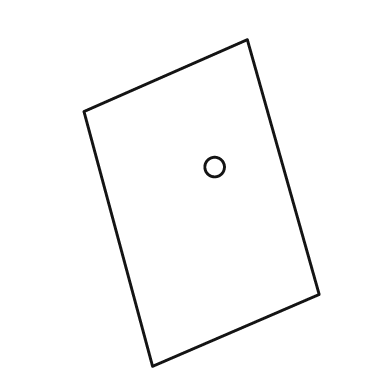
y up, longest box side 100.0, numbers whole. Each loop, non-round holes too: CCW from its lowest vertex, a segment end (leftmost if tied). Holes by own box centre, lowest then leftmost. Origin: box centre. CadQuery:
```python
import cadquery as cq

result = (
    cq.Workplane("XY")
    .moveTo(-15.0, -50.0)
    .lineTo(36.0, -28.0)
    .lineTo(14.0, 50.0)
    .lineTo(-36.0, 28.0)
    .close()
    .moveTo(4.0, 11.0)
    .circle(3.0)
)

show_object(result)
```